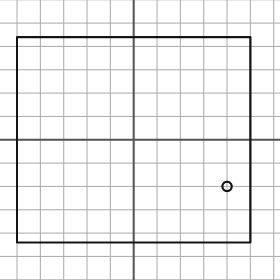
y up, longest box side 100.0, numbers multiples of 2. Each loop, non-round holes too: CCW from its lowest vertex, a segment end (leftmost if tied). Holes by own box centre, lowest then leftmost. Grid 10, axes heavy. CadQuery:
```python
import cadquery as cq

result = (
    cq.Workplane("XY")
    .moveTo(-50.0, -44.0)
    .lineTo(50.0, -44.0)
    .lineTo(50.0, 44.0)
    .lineTo(-50.0, 44.0)
    .close()
    .moveTo(40.0, -20.0)
    .circle(2.0)
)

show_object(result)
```